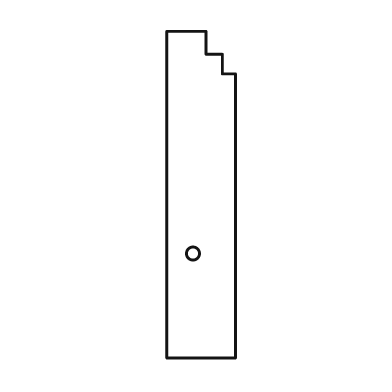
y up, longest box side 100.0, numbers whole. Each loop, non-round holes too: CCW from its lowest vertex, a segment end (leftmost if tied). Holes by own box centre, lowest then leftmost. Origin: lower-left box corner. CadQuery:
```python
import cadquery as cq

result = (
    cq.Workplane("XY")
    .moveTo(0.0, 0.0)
    .lineTo(21.0, 0.0)
    .lineTo(21.0, 87.0)
    .lineTo(17.0, 87.0)
    .lineTo(17.0, 93.0)
    .lineTo(12.0, 93.0)
    .lineTo(12.0, 100.0)
    .lineTo(0.0, 100.0)
    .close()
    .moveTo(8.0, 32.0)
    .circle(2.0)
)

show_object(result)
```